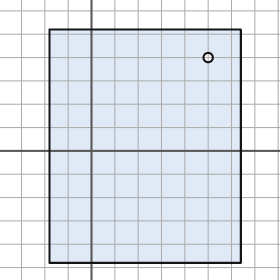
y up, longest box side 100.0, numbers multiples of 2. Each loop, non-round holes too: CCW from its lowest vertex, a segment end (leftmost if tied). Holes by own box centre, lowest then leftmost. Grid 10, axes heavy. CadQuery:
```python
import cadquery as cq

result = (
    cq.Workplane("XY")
    .moveTo(-18.0, -48.0)
    .lineTo(64.0, -48.0)
    .lineTo(64.0, 52.0)
    .lineTo(-18.0, 52.0)
    .close()
    .moveTo(50.0, 40.0)
    .circle(2.0)
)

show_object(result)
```